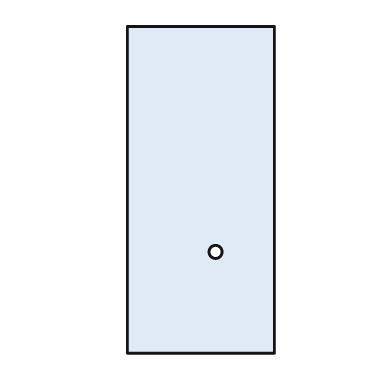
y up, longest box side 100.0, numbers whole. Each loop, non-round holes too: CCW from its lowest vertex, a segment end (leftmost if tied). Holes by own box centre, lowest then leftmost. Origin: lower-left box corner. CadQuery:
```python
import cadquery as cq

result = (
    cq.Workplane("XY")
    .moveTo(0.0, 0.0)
    .lineTo(45.0, 0.0)
    .lineTo(45.0, 100.0)
    .lineTo(0.0, 100.0)
    .close()
    .moveTo(27.0, 31.0)
    .circle(2.0)
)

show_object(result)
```